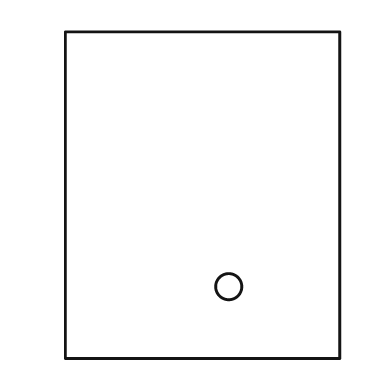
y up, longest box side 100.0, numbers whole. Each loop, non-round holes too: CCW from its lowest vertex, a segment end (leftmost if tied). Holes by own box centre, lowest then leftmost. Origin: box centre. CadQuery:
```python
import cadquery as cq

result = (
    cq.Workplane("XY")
    .moveTo(-42.0, -50.0)
    .lineTo(42.0, -50.0)
    .lineTo(42.0, 50.0)
    .lineTo(-42.0, 50.0)
    .close()
    .moveTo(8.0, -28.0)
    .circle(4.0)
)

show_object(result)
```